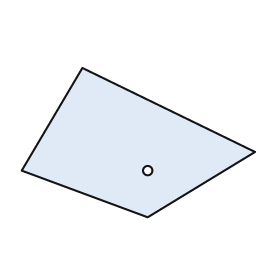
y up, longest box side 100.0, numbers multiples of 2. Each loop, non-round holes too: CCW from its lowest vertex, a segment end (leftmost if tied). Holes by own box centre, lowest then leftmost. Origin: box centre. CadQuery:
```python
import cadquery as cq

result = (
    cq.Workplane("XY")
    .moveTo(4.0, -32.0)
    .lineTo(50.0, -4.0)
    .lineTo(-24.0, 32.0)
    .lineTo(-50.0, -12.0)
    .close()
    .moveTo(4.0, -12.0)
    .circle(2.0)
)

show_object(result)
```